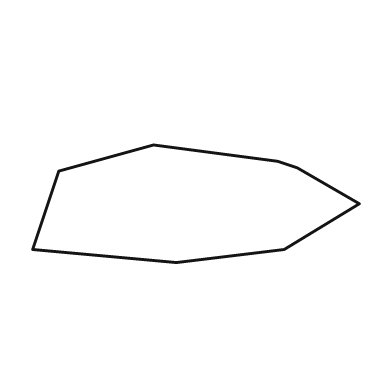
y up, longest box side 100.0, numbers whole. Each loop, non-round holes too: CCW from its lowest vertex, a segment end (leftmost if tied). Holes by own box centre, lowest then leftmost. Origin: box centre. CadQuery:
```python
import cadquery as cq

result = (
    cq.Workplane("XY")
    .moveTo(-6.0, -18.0)
    .lineTo(27.0, -14.0)
    .lineTo(50.0, 0.0)
    .lineTo(31.0, 11.0)
    .lineTo(25.0, 13.0)
    .lineTo(-13.0, 18.0)
    .lineTo(-42.0, 10.0)
    .lineTo(-50.0, -14.0)
    .close()
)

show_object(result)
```